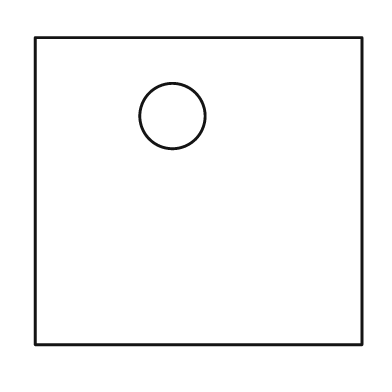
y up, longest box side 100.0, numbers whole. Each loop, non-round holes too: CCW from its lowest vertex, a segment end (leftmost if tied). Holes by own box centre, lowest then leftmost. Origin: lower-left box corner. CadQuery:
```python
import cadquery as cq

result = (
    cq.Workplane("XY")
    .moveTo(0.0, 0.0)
    .lineTo(100.0, 0.0)
    .lineTo(100.0, 94.0)
    .lineTo(0.0, 94.0)
    .close()
    .moveTo(42.0, 70.0)
    .circle(10.0)
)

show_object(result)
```